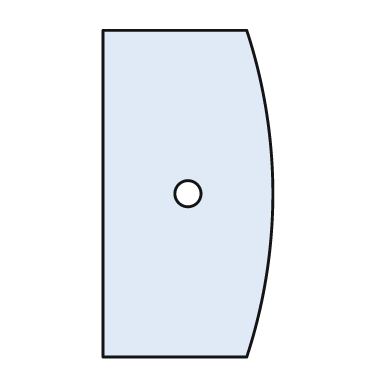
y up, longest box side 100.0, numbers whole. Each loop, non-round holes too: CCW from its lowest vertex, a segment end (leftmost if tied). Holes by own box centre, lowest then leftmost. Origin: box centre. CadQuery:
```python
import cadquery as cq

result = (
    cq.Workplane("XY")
    .moveTo(-26.0, -50.0)
    .lineTo(18.0, -50.0)
    .threePointArc((26.0, 0.0), (18.0, 50.0))
    .lineTo(-26.0, 50.0)
    .close()
    .moveTo(0.0, 0.0)
    .circle(4.0)
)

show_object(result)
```